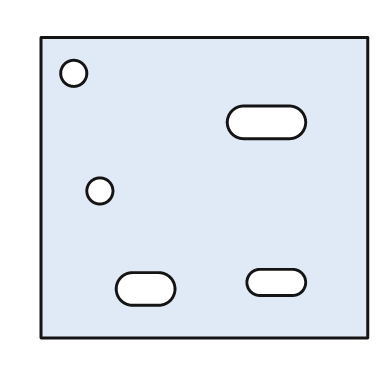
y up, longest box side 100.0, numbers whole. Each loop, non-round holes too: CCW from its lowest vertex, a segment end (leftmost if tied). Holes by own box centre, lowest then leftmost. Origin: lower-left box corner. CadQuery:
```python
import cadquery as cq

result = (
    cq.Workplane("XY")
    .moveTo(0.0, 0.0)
    .lineTo(100.0, 0.0)
    .lineTo(100.0, 92.0)
    .lineTo(0.0, 92.0)
    .close()
    .moveTo(28.0, 10.0)
    .lineTo(36.0, 10.0)
    .threePointArc((41.0, 15.0), (36.0, 20.0))
    .lineTo(28.0, 20.0)
    .threePointArc((23.0, 15.0), (28.0, 10.0))
    .close()
    .moveTo(67.0, 13.0)
    .lineTo(77.0, 13.0)
    .threePointArc((81.0, 17.0), (77.0, 21.0))
    .lineTo(67.0, 21.0)
    .threePointArc((63.0, 17.0), (67.0, 13.0))
    .close()
    .moveTo(18.0, 45.0)
    .circle(4.0)
    .moveTo(62.0, 61.0)
    .lineTo(76.0, 61.0)
    .threePointArc((81.0, 66.0), (76.0, 71.0))
    .lineTo(62.0, 71.0)
    .threePointArc((57.0, 66.0), (62.0, 61.0))
    .close()
    .moveTo(10.0, 81.0)
    .circle(4.0)
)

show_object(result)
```